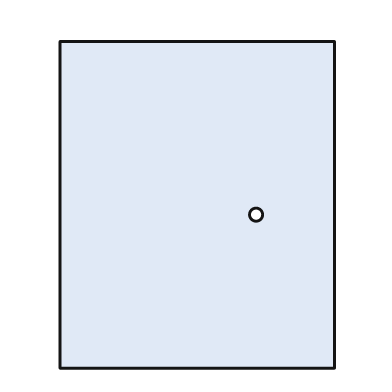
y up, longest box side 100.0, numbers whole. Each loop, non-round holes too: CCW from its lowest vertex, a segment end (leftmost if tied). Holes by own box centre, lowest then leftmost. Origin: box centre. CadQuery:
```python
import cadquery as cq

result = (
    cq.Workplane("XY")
    .moveTo(-42.0, -50.0)
    .lineTo(42.0, -50.0)
    .lineTo(42.0, 50.0)
    .lineTo(-42.0, 50.0)
    .close()
    .moveTo(18.0, -3.0)
    .circle(2.0)
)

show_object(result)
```